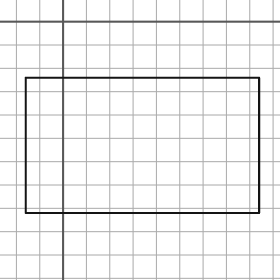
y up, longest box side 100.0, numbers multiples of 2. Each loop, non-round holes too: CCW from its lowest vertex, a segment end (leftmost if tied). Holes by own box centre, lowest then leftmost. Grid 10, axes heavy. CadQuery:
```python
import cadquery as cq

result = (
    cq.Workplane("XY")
    .moveTo(-16.0, -82.0)
    .lineTo(84.0, -82.0)
    .lineTo(84.0, -24.0)
    .lineTo(-16.0, -24.0)
    .close()
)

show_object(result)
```